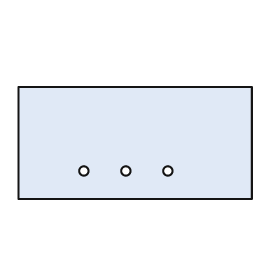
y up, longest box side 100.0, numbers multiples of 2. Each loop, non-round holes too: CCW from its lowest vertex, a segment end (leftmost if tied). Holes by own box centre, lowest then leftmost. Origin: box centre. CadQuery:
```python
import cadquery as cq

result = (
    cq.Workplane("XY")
    .moveTo(-50.0, -24.0)
    .lineTo(50.0, -24.0)
    .lineTo(50.0, 24.0)
    .lineTo(-50.0, 24.0)
    .close()
    .moveTo(-22.0, -12.0)
    .circle(2.0)
    .moveTo(-4.0, -12.0)
    .circle(2.0)
    .moveTo(14.0, -12.0)
    .circle(2.0)
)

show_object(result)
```